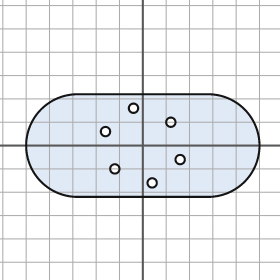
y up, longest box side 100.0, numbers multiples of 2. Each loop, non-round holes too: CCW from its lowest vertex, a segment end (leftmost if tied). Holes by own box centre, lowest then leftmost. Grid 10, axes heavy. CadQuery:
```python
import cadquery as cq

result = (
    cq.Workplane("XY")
    .moveTo(-28.0, -22.0)
    .lineTo(28.0, -22.0)
    .threePointArc((50.0, 0.0), (28.0, 22.0))
    .lineTo(-28.0, 22.0)
    .threePointArc((-50.0, 0.0), (-28.0, -22.0))
    .close()
    .moveTo(4.0, -16.0)
    .circle(2.0)
    .moveTo(-12.0, -10.0)
    .circle(2.0)
    .moveTo(16.0, -6.0)
    .circle(2.0)
    .moveTo(-16.0, 6.0)
    .circle(2.0)
    .moveTo(12.0, 10.0)
    .circle(2.0)
    .moveTo(-4.0, 16.0)
    .circle(2.0)
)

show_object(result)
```